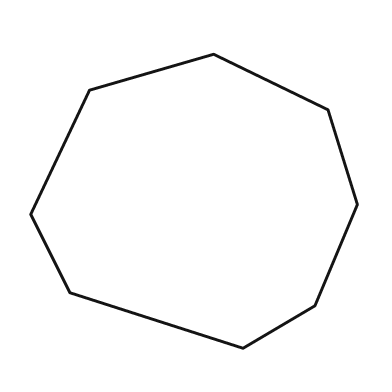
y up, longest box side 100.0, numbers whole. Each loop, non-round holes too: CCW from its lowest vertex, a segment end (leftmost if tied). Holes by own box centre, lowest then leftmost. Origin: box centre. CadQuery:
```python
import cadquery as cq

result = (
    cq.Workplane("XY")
    .moveTo(15.0, -45.0)
    .lineTo(37.0, -32.0)
    .lineTo(50.0, -1.0)
    .lineTo(41.0, 28.0)
    .lineTo(6.0, 45.0)
    .lineTo(-32.0, 34.0)
    .lineTo(-50.0, -4.0)
    .lineTo(-38.0, -28.0)
    .close()
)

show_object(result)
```